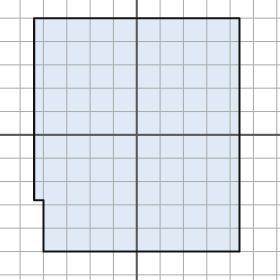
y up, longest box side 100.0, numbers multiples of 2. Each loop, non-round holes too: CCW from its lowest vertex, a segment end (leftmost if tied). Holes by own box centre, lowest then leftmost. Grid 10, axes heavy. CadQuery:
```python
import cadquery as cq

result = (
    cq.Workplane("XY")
    .moveTo(-40.0, -50.0)
    .lineTo(44.0, -50.0)
    .lineTo(44.0, 50.0)
    .lineTo(-44.0, 50.0)
    .lineTo(-44.0, -28.0)
    .lineTo(-40.0, -28.0)
    .close()
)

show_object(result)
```